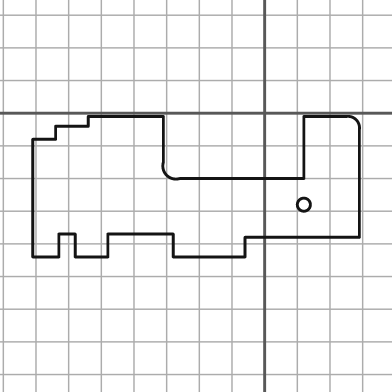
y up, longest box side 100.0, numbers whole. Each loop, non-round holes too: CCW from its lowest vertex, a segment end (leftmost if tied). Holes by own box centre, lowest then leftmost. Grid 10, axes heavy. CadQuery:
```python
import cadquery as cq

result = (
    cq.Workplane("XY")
    .moveTo(-71.0, -44.0)
    .lineTo(-63.0, -44.0)
    .lineTo(-63.0, -37.0)
    .lineTo(-58.0, -37.0)
    .lineTo(-58.0, -44.0)
    .lineTo(-48.0, -44.0)
    .lineTo(-48.0, -37.0)
    .lineTo(-28.0, -37.0)
    .lineTo(-28.0, -44.0)
    .lineTo(-6.0, -44.0)
    .lineTo(-6.0, -38.0)
    .lineTo(29.0, -38.0)
    .lineTo(29.0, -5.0)
    .threePointArc((28.0, -2.0), (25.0, -1.0))
    .lineTo(12.0, -1.0)
    .lineTo(12.0, -20.0)
    .lineTo(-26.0, -20.0)
    .threePointArc((-30.0, -19.0), (-31.0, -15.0))
    .lineTo(-31.0, -1.0)
    .lineTo(-54.0, -1.0)
    .lineTo(-54.0, -4.0)
    .lineTo(-64.0, -4.0)
    .lineTo(-64.0, -8.0)
    .lineTo(-71.0, -8.0)
    .close()
    .moveTo(12.0, -28.0)
    .circle(2.0)
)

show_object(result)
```